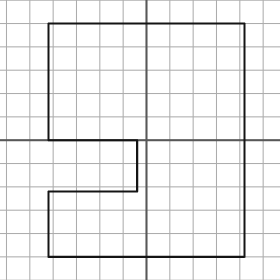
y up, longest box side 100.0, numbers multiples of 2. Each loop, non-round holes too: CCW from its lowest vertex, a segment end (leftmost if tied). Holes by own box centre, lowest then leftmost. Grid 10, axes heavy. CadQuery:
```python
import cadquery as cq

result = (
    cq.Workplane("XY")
    .moveTo(-42.0, -50.0)
    .lineTo(42.0, -50.0)
    .lineTo(42.0, 50.0)
    .lineTo(-42.0, 50.0)
    .lineTo(-42.0, 0.0)
    .lineTo(-4.0, 0.0)
    .lineTo(-4.0, -22.0)
    .lineTo(-42.0, -22.0)
    .close()
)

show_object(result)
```